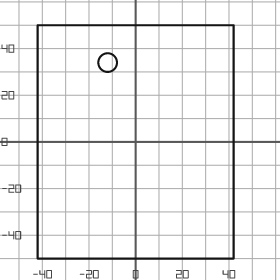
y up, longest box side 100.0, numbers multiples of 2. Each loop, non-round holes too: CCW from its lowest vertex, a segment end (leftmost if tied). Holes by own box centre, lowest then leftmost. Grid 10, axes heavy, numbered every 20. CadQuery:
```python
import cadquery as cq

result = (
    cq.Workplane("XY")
    .moveTo(-42.0, -50.0)
    .lineTo(42.0, -50.0)
    .lineTo(42.0, 50.0)
    .lineTo(-42.0, 50.0)
    .close()
    .moveTo(-12.0, 34.0)
    .circle(4.0)
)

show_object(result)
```